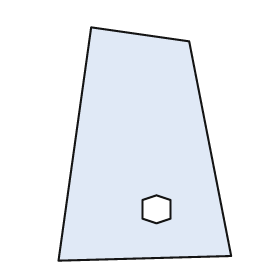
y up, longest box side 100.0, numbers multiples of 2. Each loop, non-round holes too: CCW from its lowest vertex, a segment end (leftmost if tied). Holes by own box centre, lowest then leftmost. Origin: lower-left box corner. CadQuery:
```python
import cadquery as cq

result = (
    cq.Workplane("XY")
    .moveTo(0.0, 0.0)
    .lineTo(74.0, 2.0)
    .lineTo(56.0, 94.0)
    .lineTo(14.0, 100.0)
    .close()
    .moveTo(42.0, 16.0)
    .lineTo(48.0, 18.0)
    .lineTo(48.0, 26.0)
    .lineTo(42.0, 28.0)
    .lineTo(36.0, 26.0)
    .lineTo(36.0, 18.0)
    .close()
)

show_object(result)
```